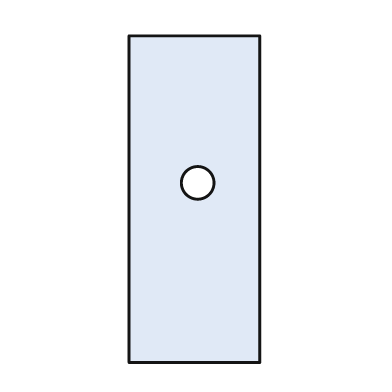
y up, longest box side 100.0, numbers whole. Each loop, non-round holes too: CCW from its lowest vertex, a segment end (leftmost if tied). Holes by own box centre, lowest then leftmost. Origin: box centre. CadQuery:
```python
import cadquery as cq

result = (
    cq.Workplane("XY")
    .moveTo(-20.0, -50.0)
    .lineTo(20.0, -50.0)
    .lineTo(20.0, 50.0)
    .lineTo(-20.0, 50.0)
    .close()
    .moveTo(1.0, 5.0)
    .circle(5.0)
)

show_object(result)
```